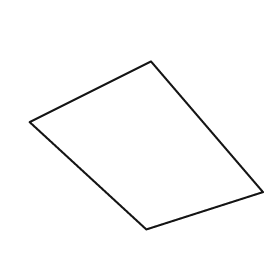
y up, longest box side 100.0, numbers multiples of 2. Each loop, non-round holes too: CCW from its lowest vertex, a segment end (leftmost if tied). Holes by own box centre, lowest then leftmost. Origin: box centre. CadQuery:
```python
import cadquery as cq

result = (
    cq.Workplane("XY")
    .moveTo(0.0, -36.0)
    .lineTo(50.0, -20.0)
    .lineTo(2.0, 36.0)
    .lineTo(-50.0, 10.0)
    .close()
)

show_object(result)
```